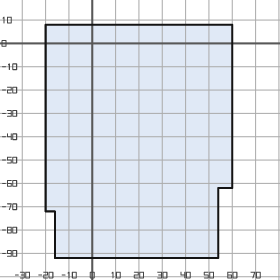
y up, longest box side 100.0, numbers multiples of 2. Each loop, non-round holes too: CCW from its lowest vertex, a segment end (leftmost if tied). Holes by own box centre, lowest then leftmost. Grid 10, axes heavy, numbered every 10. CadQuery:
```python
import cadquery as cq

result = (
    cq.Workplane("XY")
    .moveTo(-16.0, -92.0)
    .lineTo(54.0, -92.0)
    .lineTo(54.0, -62.0)
    .lineTo(60.0, -62.0)
    .lineTo(60.0, 8.0)
    .lineTo(-20.0, 8.0)
    .lineTo(-20.0, -72.0)
    .lineTo(-16.0, -72.0)
    .close()
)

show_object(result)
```